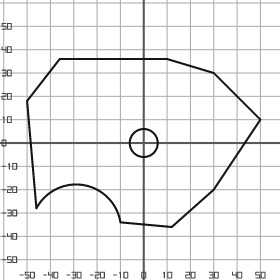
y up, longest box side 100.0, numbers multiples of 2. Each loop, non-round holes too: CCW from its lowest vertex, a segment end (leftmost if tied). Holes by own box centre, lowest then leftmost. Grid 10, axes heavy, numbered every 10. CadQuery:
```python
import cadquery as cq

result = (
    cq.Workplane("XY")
    .moveTo(12.0, -36.0)
    .lineTo(30.0, -20.0)
    .lineTo(50.0, 10.0)
    .lineTo(30.0, 30.0)
    .lineTo(10.0, 36.0)
    .lineTo(-36.0, 36.0)
    .lineTo(-50.0, 18.0)
    .lineTo(-46.0, -28.0)
    .threePointArc((-26.0, -18.0), (-10.0, -34.0))
    .close()
    .moveTo(0.0, 0.0)
    .circle(6.0)
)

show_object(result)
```